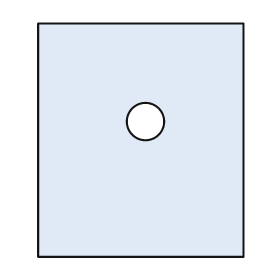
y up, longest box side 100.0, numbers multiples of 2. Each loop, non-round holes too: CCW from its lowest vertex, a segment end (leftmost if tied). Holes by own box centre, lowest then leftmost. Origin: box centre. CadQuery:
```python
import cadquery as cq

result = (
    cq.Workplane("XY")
    .moveTo(-44.0, -50.0)
    .lineTo(44.0, -50.0)
    .lineTo(44.0, 50.0)
    .lineTo(-44.0, 50.0)
    .close()
    .moveTo(2.0, 8.0)
    .circle(8.0)
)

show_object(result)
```